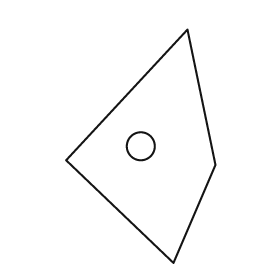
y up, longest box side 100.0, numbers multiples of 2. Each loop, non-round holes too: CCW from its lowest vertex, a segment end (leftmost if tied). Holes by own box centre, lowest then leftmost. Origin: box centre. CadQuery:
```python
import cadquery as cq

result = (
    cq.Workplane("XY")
    .moveTo(14.0, -50.0)
    .lineTo(32.0, -8.0)
    .lineTo(20.0, 50.0)
    .lineTo(-32.0, -6.0)
    .close()
    .moveTo(0.0, 0.0)
    .circle(6.0)
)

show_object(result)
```